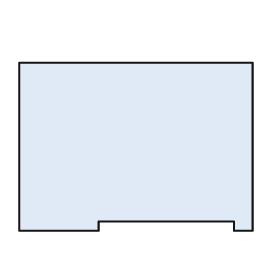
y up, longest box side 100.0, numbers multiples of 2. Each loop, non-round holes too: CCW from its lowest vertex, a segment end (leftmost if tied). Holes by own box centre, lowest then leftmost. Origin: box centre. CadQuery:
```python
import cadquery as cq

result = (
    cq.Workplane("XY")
    .moveTo(-50.0, -36.0)
    .lineTo(-16.0, -36.0)
    .lineTo(-16.0, -32.0)
    .lineTo(42.0, -32.0)
    .lineTo(42.0, -36.0)
    .lineTo(50.0, -36.0)
    .lineTo(50.0, 36.0)
    .lineTo(-50.0, 36.0)
    .close()
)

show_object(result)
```